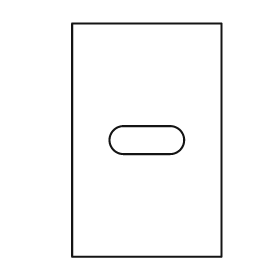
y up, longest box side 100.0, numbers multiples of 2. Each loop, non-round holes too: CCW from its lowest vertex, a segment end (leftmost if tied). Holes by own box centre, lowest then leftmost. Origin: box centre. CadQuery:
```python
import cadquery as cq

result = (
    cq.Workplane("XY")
    .moveTo(-32.0, -50.0)
    .lineTo(32.0, -50.0)
    .lineTo(32.0, 50.0)
    .lineTo(-32.0, 50.0)
    .close()
    .moveTo(-10.0, -6.0)
    .lineTo(10.0, -6.0)
    .threePointArc((16.0, 0.0), (10.0, 6.0))
    .lineTo(-10.0, 6.0)
    .threePointArc((-16.0, 0.0), (-10.0, -6.0))
    .close()
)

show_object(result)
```